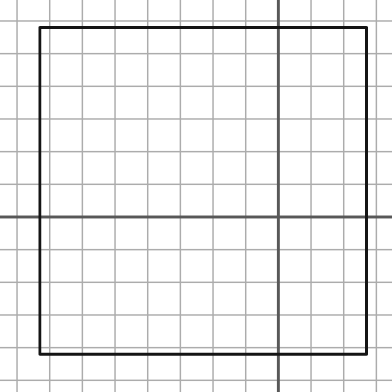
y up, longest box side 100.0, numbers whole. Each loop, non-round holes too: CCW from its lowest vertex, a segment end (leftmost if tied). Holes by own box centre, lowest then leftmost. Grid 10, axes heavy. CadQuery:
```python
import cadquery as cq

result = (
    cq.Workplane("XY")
    .moveTo(-73.0, -42.0)
    .lineTo(27.0, -42.0)
    .lineTo(27.0, 58.0)
    .lineTo(-73.0, 58.0)
    .close()
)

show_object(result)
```